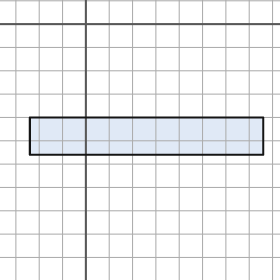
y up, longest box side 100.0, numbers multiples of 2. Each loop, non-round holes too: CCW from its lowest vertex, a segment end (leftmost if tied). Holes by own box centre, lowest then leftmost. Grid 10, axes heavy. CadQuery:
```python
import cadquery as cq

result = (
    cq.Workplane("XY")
    .moveTo(-24.0, -56.0)
    .lineTo(76.0, -56.0)
    .lineTo(76.0, -40.0)
    .lineTo(-24.0, -40.0)
    .close()
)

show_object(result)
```